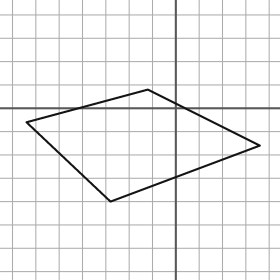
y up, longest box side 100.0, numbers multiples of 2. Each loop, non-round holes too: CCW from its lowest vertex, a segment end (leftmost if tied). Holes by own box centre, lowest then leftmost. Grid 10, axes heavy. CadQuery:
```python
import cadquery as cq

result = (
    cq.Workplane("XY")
    .moveTo(-28.0, -40.0)
    .lineTo(36.0, -16.0)
    .lineTo(-12.0, 8.0)
    .lineTo(-64.0, -6.0)
    .close()
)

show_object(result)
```